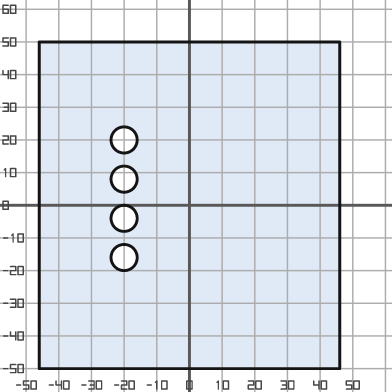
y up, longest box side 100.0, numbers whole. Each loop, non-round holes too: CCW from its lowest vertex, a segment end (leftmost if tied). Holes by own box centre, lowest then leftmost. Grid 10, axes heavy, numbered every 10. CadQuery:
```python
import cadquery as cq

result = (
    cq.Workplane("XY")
    .moveTo(-46.0, -50.0)
    .lineTo(46.0, -50.0)
    .lineTo(46.0, 50.0)
    .lineTo(-46.0, 50.0)
    .close()
    .moveTo(-20.0, -16.0)
    .circle(4.0)
    .moveTo(-20.0, -4.0)
    .circle(4.0)
    .moveTo(-20.0, 8.0)
    .circle(4.0)
    .moveTo(-20.0, 20.0)
    .circle(4.0)
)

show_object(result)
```